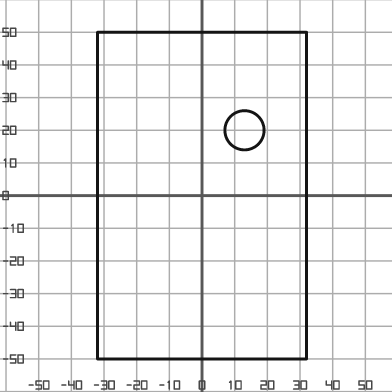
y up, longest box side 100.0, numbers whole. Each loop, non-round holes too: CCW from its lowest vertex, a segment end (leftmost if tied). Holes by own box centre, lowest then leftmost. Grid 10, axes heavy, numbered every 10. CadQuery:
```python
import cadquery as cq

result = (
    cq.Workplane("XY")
    .moveTo(-32.0, -50.0)
    .lineTo(32.0, -50.0)
    .lineTo(32.0, 50.0)
    .lineTo(-32.0, 50.0)
    .close()
    .moveTo(13.0, 20.0)
    .circle(6.0)
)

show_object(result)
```